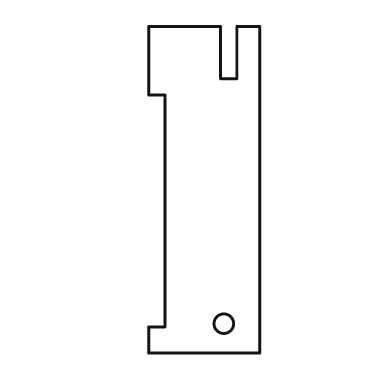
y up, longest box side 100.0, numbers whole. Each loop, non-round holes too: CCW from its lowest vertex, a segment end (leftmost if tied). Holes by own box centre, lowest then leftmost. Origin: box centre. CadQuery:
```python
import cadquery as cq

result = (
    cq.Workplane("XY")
    .moveTo(-17.0, -50.0)
    .lineTo(17.0, -50.0)
    .lineTo(17.0, 50.0)
    .lineTo(10.0, 50.0)
    .lineTo(10.0, 34.0)
    .lineTo(5.0, 34.0)
    .lineTo(5.0, 50.0)
    .lineTo(-17.0, 50.0)
    .lineTo(-17.0, 29.0)
    .lineTo(-12.0, 29.0)
    .lineTo(-12.0, -42.0)
    .lineTo(-17.0, -42.0)
    .close()
    .moveTo(6.0, -41.0)
    .circle(3.0)
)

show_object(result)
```